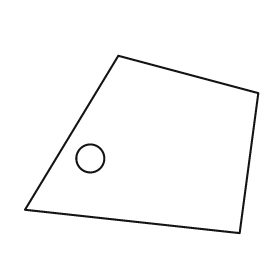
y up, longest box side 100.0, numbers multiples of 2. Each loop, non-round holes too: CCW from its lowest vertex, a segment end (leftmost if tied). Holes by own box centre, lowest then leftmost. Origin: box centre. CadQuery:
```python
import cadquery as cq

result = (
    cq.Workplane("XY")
    .moveTo(42.0, -38.0)
    .lineTo(50.0, 22.0)
    .lineTo(-10.0, 38.0)
    .lineTo(-50.0, -28.0)
    .close()
    .moveTo(-22.0, -6.0)
    .circle(6.0)
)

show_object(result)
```